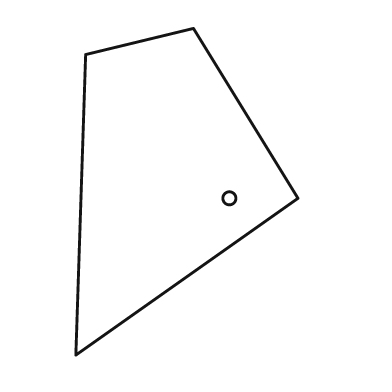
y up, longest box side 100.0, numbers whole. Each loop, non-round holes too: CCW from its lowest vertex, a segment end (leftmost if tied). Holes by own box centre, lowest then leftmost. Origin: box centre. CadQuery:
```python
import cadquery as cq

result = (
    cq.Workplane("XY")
    .moveTo(-34.0, -50.0)
    .lineTo(34.0, -2.0)
    .lineTo(2.0, 50.0)
    .lineTo(-31.0, 42.0)
    .close()
    .moveTo(13.0, -2.0)
    .circle(2.0)
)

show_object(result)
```